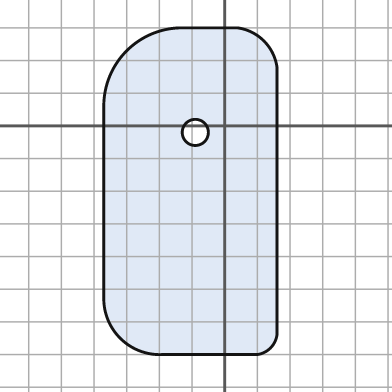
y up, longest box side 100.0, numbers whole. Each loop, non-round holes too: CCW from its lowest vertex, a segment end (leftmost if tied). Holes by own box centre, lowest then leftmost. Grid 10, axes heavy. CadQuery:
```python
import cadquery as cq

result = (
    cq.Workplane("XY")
    .moveTo(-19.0, -70.0)
    .lineTo(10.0, -70.0)
    .threePointArc((14.0, -68.0), (16.0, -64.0))
    .lineTo(16.0, 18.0)
    .threePointArc((12.0, 26.0), (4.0, 30.0))
    .lineTo(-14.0, 30.0)
    .threePointArc((-30.0, 23.0), (-37.0, 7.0))
    .lineTo(-37.0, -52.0)
    .threePointArc((-32.0, -65.0), (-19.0, -70.0))
    .close()
    .moveTo(-9.0, -2.0)
    .circle(4.0)
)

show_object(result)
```